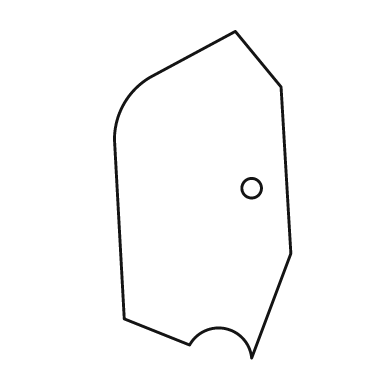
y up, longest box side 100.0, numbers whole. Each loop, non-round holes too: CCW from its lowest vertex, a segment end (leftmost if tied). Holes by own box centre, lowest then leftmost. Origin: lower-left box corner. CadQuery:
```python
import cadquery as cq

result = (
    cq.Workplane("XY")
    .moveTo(42.0, 0.0)
    .lineTo(54.0, 32.0)
    .lineTo(51.0, 83.0)
    .lineTo(37.0, 100.0)
    .lineTo(11.0, 86.0)
    .threePointArc((3.0, 78.0), (0.0, 67.0))
    .lineTo(3.0, 12.0)
    .lineTo(23.0, 4.0)
    .threePointArc((34.0, 9.0), (42.0, 0.0))
    .close()
    .moveTo(42.0, 52.0)
    .circle(3.0)
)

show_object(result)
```